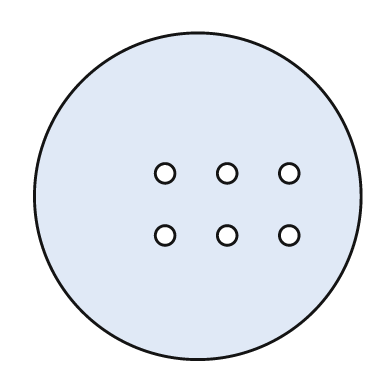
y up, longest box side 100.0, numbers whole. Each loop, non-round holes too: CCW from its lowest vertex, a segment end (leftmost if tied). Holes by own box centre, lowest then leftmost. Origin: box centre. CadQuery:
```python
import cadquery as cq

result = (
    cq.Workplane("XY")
    .moveTo(0.0, 0.0)
    .circle(50.0)
    .moveTo(-10.0, -12.0)
    .circle(3.0)
    .moveTo(9.0, -12.0)
    .circle(3.0)
    .moveTo(28.0, -12.0)
    .circle(3.0)
    .moveTo(-10.0, 7.0)
    .circle(3.0)
    .moveTo(9.0, 7.0)
    .circle(3.0)
    .moveTo(28.0, 7.0)
    .circle(3.0)
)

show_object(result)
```